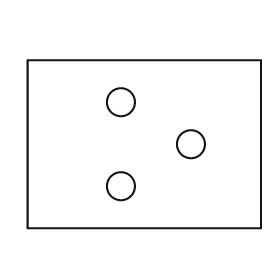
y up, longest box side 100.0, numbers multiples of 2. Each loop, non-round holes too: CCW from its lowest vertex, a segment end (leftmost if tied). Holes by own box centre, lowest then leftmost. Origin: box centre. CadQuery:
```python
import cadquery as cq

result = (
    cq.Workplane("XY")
    .moveTo(-50.0, -36.0)
    .lineTo(50.0, -36.0)
    .lineTo(50.0, 36.0)
    .lineTo(-50.0, 36.0)
    .close()
    .moveTo(-10.0, -18.0)
    .circle(6.0)
    .moveTo(20.0, 0.0)
    .circle(6.0)
    .moveTo(-10.0, 18.0)
    .circle(6.0)
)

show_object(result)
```